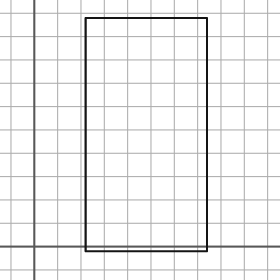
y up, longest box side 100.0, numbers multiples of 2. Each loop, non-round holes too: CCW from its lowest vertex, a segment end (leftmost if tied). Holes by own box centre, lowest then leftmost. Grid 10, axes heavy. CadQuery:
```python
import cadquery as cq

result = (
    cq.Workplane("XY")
    .moveTo(22.0, -2.0)
    .lineTo(74.0, -2.0)
    .lineTo(74.0, 98.0)
    .lineTo(22.0, 98.0)
    .close()
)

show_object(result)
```